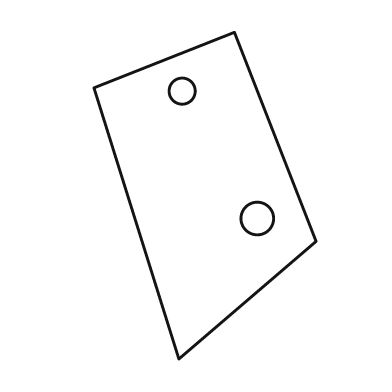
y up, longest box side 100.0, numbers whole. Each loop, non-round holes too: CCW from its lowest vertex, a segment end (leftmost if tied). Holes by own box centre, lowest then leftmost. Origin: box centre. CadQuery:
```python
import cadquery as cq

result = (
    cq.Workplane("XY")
    .moveTo(-8.0, -50.0)
    .lineTo(34.0, -14.0)
    .lineTo(9.0, 50.0)
    .lineTo(-34.0, 33.0)
    .close()
    .moveTo(16.0, -7.0)
    .circle(5.0)
    .moveTo(-7.0, 32.0)
    .circle(4.0)
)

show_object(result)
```